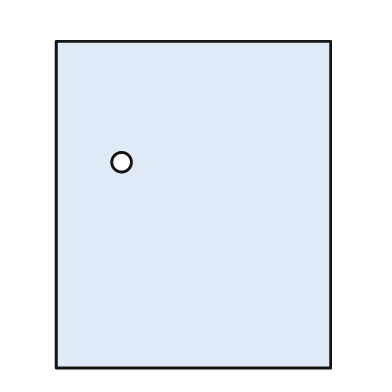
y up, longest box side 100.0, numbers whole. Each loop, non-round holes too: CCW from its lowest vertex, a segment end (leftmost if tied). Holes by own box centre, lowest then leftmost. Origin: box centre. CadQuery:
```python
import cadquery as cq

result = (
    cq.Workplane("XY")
    .moveTo(-42.0, -50.0)
    .lineTo(42.0, -50.0)
    .lineTo(42.0, 50.0)
    .lineTo(-42.0, 50.0)
    .close()
    .moveTo(-22.0, 13.0)
    .circle(3.0)
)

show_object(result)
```